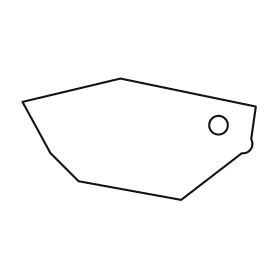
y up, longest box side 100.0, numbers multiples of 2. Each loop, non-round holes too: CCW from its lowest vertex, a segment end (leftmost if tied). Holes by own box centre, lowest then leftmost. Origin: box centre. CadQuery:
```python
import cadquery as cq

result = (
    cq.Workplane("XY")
    .moveTo(18.0, -26.0)
    .lineTo(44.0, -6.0)
    .threePointArc((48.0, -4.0), (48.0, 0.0))
    .lineTo(50.0, 14.0)
    .lineTo(-8.0, 26.0)
    .lineTo(-50.0, 16.0)
    .lineTo(-38.0, -6.0)
    .lineTo(-26.0, -18.0)
    .close()
    .moveTo(34.0, 6.0)
    .circle(4.0)
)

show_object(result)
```